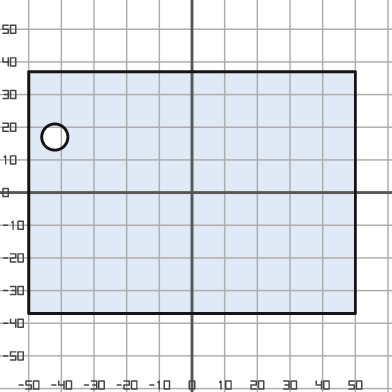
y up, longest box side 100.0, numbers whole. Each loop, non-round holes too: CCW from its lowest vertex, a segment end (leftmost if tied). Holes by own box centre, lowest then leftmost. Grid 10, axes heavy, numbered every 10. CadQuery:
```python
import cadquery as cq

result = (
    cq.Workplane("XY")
    .moveTo(-50.0, -37.0)
    .lineTo(50.0, -37.0)
    .lineTo(50.0, 37.0)
    .lineTo(-50.0, 37.0)
    .close()
    .moveTo(-42.0, 17.0)
    .circle(4.0)
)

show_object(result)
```